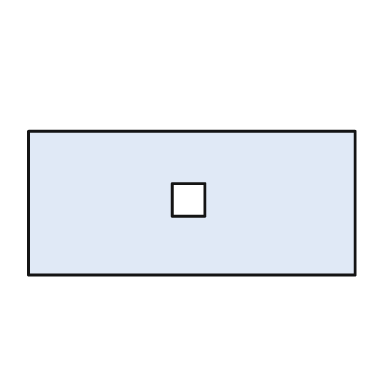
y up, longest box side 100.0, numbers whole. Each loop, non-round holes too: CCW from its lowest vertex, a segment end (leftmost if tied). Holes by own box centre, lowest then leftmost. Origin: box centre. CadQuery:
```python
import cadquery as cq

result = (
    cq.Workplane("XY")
    .moveTo(-50.0, -22.0)
    .lineTo(50.0, -22.0)
    .lineTo(50.0, 22.0)
    .lineTo(-50.0, 22.0)
    .close()
    .moveTo(-6.0, -4.0)
    .lineTo(4.0, -4.0)
    .lineTo(4.0, 6.0)
    .lineTo(-6.0, 6.0)
    .close()
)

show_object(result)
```